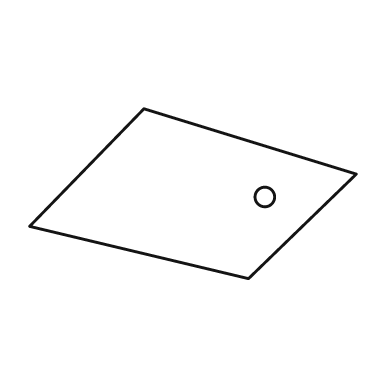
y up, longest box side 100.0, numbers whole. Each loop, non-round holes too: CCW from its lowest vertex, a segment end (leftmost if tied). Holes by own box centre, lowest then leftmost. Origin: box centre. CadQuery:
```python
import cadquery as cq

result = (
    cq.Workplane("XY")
    .moveTo(17.0, -26.0)
    .lineTo(50.0, 6.0)
    .lineTo(-15.0, 26.0)
    .lineTo(-50.0, -10.0)
    .close()
    .moveTo(22.0, -1.0)
    .circle(3.0)
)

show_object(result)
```